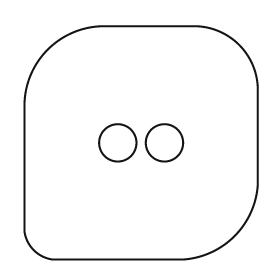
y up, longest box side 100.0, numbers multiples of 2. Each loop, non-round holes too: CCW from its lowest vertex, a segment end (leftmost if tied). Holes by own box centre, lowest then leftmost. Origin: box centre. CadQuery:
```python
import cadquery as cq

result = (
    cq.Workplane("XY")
    .moveTo(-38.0, -50.0)
    .lineTo(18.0, -50.0)
    .threePointArc((40.0, -40.0), (50.0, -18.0))
    .lineTo(50.0, 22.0)
    .threePointArc((42.0, 42.0), (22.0, 50.0))
    .lineTo(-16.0, 50.0)
    .threePointArc((-40.0, 40.0), (-50.0, 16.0))
    .lineTo(-50.0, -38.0)
    .threePointArc((-46.0, -46.0), (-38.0, -50.0))
    .close()
    .moveTo(-10.0, 0.0)
    .circle(8.0)
    .moveTo(10.0, 0.0)
    .circle(8.0)
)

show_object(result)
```